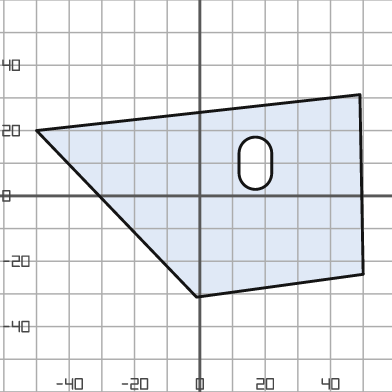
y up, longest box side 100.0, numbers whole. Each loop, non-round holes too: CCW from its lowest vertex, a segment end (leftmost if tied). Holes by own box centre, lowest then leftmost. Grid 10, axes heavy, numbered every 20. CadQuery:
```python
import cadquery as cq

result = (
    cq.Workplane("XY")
    .moveTo(-1.0, -31.0)
    .lineTo(50.0, -24.0)
    .lineTo(49.0, 31.0)
    .lineTo(-50.0, 20.0)
    .close()
    .moveTo(12.0, 7.0)
    .threePointArc((17.0, 2.0), (22.0, 7.0))
    .lineTo(22.0, 13.0)
    .threePointArc((17.0, 18.0), (12.0, 13.0))
    .close()
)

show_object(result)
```